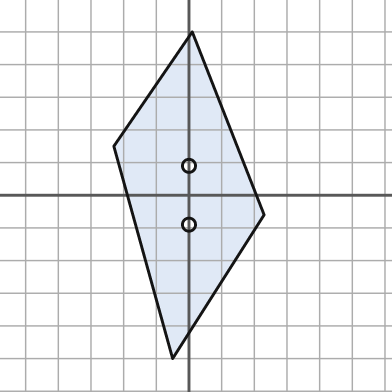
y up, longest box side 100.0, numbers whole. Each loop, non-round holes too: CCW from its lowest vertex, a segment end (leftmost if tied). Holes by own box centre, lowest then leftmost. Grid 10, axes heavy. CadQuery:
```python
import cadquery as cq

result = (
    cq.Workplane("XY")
    .moveTo(-5.0, -50.0)
    .lineTo(23.0, -6.0)
    .lineTo(1.0, 50.0)
    .lineTo(-23.0, 15.0)
    .close()
    .moveTo(0.0, -9.0)
    .circle(2.0)
    .moveTo(0.0, 9.0)
    .circle(2.0)
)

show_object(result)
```